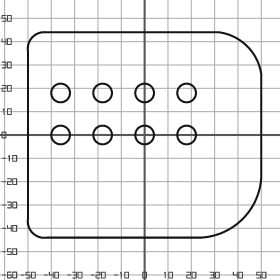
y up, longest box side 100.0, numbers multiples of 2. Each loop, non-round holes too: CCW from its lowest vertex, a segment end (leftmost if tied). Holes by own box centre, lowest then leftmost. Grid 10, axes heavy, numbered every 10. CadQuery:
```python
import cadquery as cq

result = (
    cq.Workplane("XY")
    .moveTo(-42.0, -44.0)
    .lineTo(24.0, -44.0)
    .threePointArc((42.0, -36.0), (50.0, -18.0))
    .lineTo(50.0, 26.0)
    .threePointArc((44.0, 38.0), (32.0, 44.0))
    .lineTo(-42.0, 44.0)
    .threePointArc((-48.0, 42.0), (-50.0, 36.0))
    .lineTo(-50.0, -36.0)
    .threePointArc((-48.0, -42.0), (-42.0, -44.0))
    .close()
    .moveTo(-36.0, 0.0)
    .circle(4.0)
    .moveTo(-18.0, 0.0)
    .circle(4.0)
    .moveTo(0.0, 0.0)
    .circle(4.0)
    .moveTo(18.0, 0.0)
    .circle(4.0)
    .moveTo(-36.0, 18.0)
    .circle(4.0)
    .moveTo(-18.0, 18.0)
    .circle(4.0)
    .moveTo(0.0, 18.0)
    .circle(4.0)
    .moveTo(18.0, 18.0)
    .circle(4.0)
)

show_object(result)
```